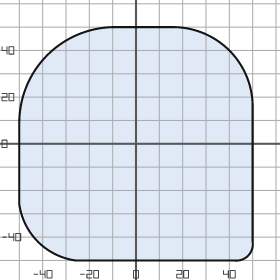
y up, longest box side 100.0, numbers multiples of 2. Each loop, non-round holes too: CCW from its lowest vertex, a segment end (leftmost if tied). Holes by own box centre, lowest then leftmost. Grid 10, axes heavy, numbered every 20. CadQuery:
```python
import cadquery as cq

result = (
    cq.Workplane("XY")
    .moveTo(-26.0, -50.0)
    .lineTo(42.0, -50.0)
    .threePointArc((48.0, -48.0), (50.0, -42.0))
    .lineTo(50.0, 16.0)
    .threePointArc((40.0, 40.0), (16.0, 50.0))
    .lineTo(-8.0, 50.0)
    .threePointArc((-38.0, 38.0), (-50.0, 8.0))
    .lineTo(-50.0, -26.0)
    .threePointArc((-42.0, -42.0), (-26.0, -50.0))
    .close()
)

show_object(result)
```